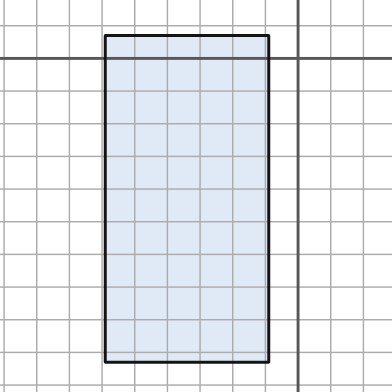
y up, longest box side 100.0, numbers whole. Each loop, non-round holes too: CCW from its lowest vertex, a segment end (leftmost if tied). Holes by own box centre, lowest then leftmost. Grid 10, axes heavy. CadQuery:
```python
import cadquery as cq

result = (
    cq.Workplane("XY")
    .moveTo(-59.0, -93.0)
    .lineTo(-9.0, -93.0)
    .lineTo(-9.0, 7.0)
    .lineTo(-59.0, 7.0)
    .close()
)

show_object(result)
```